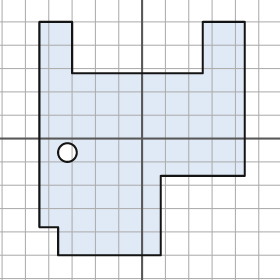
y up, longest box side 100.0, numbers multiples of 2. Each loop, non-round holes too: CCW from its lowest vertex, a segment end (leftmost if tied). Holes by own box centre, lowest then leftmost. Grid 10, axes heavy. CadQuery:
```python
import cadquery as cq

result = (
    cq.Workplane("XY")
    .moveTo(-36.0, -50.0)
    .lineTo(8.0, -50.0)
    .lineTo(8.0, -16.0)
    .lineTo(44.0, -16.0)
    .lineTo(44.0, 50.0)
    .lineTo(26.0, 50.0)
    .lineTo(26.0, 28.0)
    .lineTo(-30.0, 28.0)
    .lineTo(-30.0, 50.0)
    .lineTo(-44.0, 50.0)
    .lineTo(-44.0, -38.0)
    .lineTo(-36.0, -38.0)
    .close()
    .moveTo(-32.0, -6.0)
    .circle(4.0)
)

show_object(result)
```